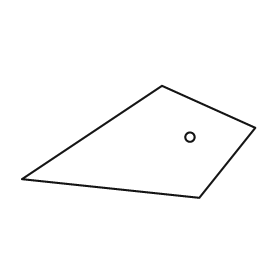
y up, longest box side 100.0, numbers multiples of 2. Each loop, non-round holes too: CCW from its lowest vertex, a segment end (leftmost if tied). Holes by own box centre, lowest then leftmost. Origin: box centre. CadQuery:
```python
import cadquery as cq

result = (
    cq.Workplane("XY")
    .moveTo(26.0, -24.0)
    .lineTo(50.0, 6.0)
    .lineTo(10.0, 24.0)
    .lineTo(-50.0, -16.0)
    .close()
    .moveTo(22.0, 2.0)
    .circle(2.0)
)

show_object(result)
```